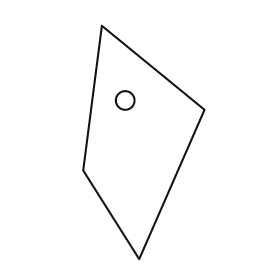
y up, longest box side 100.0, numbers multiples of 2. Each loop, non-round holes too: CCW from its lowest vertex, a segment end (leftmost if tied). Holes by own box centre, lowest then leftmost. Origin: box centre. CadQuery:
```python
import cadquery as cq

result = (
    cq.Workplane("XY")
    .moveTo(-2.0, -50.0)
    .lineTo(26.0, 14.0)
    .lineTo(-18.0, 50.0)
    .lineTo(-26.0, -12.0)
    .close()
    .moveTo(-8.0, 18.0)
    .circle(4.0)
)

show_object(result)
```